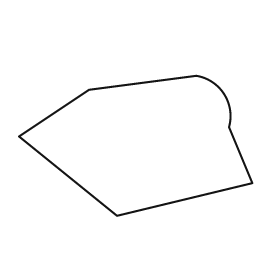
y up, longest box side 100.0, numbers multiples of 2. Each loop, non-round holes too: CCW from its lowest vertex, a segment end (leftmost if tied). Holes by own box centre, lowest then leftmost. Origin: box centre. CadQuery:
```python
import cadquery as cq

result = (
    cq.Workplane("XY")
    .moveTo(-8.0, -30.0)
    .lineTo(50.0, -16.0)
    .lineTo(40.0, 8.0)
    .threePointArc((38.0, 22.0), (26.0, 30.0))
    .lineTo(-20.0, 24.0)
    .lineTo(-50.0, 4.0)
    .close()
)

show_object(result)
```